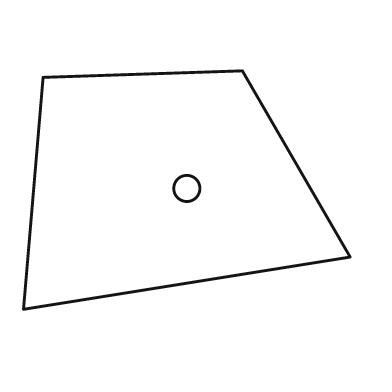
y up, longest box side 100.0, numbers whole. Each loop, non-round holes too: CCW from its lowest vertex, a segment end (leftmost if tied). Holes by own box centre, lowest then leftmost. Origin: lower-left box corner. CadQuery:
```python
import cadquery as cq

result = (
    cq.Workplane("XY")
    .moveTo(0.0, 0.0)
    .lineTo(100.0, 16.0)
    .lineTo(67.0, 73.0)
    .lineTo(6.0, 71.0)
    .close()
    .moveTo(50.0, 37.0)
    .circle(4.0)
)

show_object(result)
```